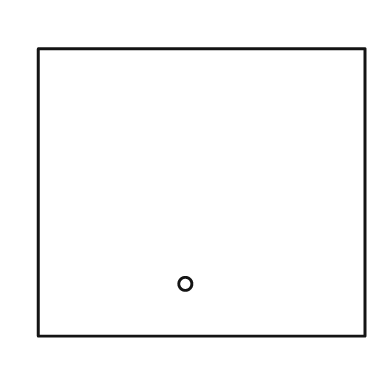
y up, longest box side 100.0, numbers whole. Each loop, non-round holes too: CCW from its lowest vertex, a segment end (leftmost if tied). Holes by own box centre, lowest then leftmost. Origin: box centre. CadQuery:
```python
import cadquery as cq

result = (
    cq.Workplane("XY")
    .moveTo(-50.0, -44.0)
    .lineTo(50.0, -44.0)
    .lineTo(50.0, 44.0)
    .lineTo(-50.0, 44.0)
    .close()
    .moveTo(-5.0, -28.0)
    .circle(2.0)
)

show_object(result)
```